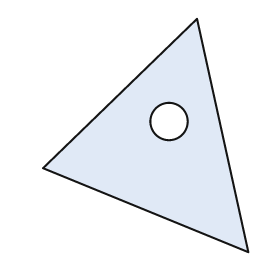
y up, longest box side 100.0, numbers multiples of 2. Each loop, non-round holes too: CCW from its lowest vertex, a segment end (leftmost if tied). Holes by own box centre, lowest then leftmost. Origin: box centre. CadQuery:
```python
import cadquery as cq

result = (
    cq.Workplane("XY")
    .moveTo(44.0, -50.0)
    .lineTo(22.0, 50.0)
    .lineTo(-44.0, -14.0)
    .close()
    .moveTo(10.0, 6.0)
    .circle(8.0)
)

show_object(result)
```